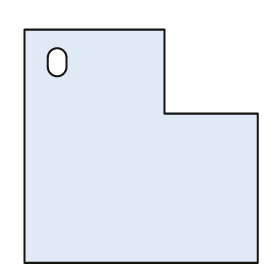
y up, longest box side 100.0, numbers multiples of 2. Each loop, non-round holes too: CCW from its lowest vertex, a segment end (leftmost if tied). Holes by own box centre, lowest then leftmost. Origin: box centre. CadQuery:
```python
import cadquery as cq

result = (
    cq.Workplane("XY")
    .moveTo(-50.0, -50.0)
    .lineTo(50.0, -50.0)
    .lineTo(50.0, 14.0)
    .lineTo(10.0, 14.0)
    .lineTo(10.0, 50.0)
    .lineTo(-50.0, 50.0)
    .close()
    .moveTo(-40.0, 34.0)
    .threePointArc((-36.0, 30.0), (-32.0, 34.0))
    .lineTo(-32.0, 38.0)
    .threePointArc((-36.0, 42.0), (-40.0, 38.0))
    .close()
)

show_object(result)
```